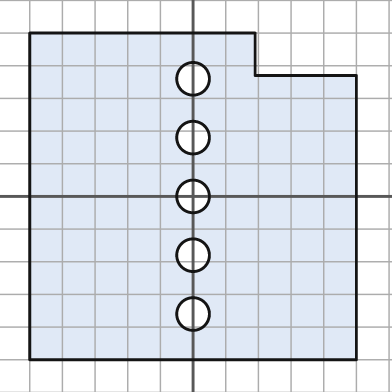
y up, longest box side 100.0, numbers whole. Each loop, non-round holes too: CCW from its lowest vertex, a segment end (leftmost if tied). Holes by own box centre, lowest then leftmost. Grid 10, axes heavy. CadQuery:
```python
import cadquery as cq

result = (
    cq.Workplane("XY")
    .moveTo(-50.0, -50.0)
    .lineTo(50.0, -50.0)
    .lineTo(50.0, 37.0)
    .lineTo(19.0, 37.0)
    .lineTo(19.0, 50.0)
    .lineTo(-50.0, 50.0)
    .close()
    .moveTo(0.0, -36.0)
    .circle(5.0)
    .moveTo(0.0, -18.0)
    .circle(5.0)
    .moveTo(0.0, 0.0)
    .circle(5.0)
    .moveTo(0.0, 18.0)
    .circle(5.0)
    .moveTo(0.0, 36.0)
    .circle(5.0)
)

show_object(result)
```